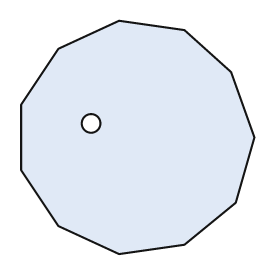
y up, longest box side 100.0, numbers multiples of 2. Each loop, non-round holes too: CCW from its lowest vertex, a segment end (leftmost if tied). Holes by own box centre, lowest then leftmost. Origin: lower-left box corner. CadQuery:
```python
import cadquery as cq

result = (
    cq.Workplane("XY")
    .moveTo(42.0, 0.0)
    .lineTo(70.0, 4.0)
    .lineTo(92.0, 22.0)
    .lineTo(100.0, 50.0)
    .lineTo(90.0, 78.0)
    .lineTo(70.0, 96.0)
    .lineTo(42.0, 100.0)
    .lineTo(16.0, 88.0)
    .lineTo(0.0, 64.0)
    .lineTo(0.0, 36.0)
    .lineTo(16.0, 12.0)
    .close()
    .moveTo(30.0, 56.0)
    .circle(4.0)
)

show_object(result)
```